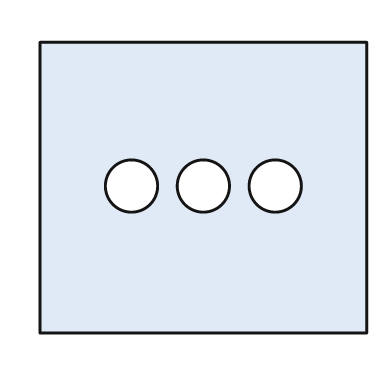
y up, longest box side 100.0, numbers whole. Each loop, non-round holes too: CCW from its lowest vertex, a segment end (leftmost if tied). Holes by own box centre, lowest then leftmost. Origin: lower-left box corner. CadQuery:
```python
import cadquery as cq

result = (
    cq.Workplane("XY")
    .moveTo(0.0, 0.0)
    .lineTo(100.0, 0.0)
    .lineTo(100.0, 89.0)
    .lineTo(0.0, 89.0)
    .close()
    .moveTo(28.0, 45.0)
    .circle(8.0)
    .moveTo(50.0, 45.0)
    .circle(8.0)
    .moveTo(72.0, 45.0)
    .circle(8.0)
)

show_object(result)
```